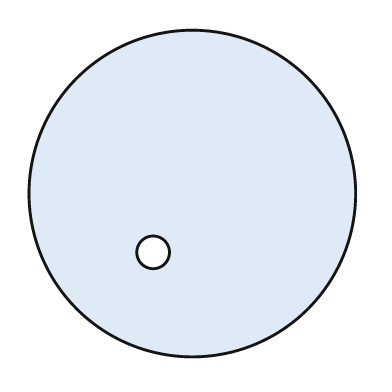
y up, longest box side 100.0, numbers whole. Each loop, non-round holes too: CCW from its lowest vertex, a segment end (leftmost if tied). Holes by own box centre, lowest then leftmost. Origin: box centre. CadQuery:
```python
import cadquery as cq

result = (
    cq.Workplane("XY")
    .moveTo(0.0, 0.0)
    .circle(50.0)
    .moveTo(-12.0, -18.0)
    .circle(5.0)
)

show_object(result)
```